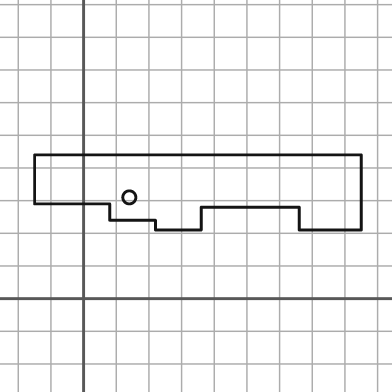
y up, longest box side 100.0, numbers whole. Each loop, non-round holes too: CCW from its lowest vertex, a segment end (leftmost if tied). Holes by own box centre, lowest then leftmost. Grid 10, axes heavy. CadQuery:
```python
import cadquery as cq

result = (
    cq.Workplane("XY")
    .moveTo(22.0, 21.0)
    .lineTo(36.0, 21.0)
    .lineTo(36.0, 28.0)
    .lineTo(66.0, 28.0)
    .lineTo(66.0, 21.0)
    .lineTo(85.0, 21.0)
    .lineTo(85.0, 44.0)
    .lineTo(-15.0, 44.0)
    .lineTo(-15.0, 29.0)
    .lineTo(8.0, 29.0)
    .lineTo(8.0, 24.0)
    .lineTo(22.0, 24.0)
    .close()
    .moveTo(14.0, 31.0)
    .circle(2.0)
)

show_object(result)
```